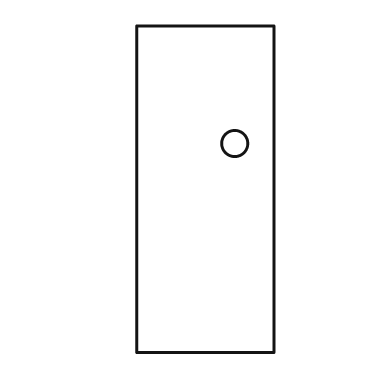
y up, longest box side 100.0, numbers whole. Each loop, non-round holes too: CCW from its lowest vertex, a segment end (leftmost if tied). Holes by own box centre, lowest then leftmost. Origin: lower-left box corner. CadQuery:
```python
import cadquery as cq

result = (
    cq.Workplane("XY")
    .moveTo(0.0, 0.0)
    .lineTo(42.0, 0.0)
    .lineTo(42.0, 100.0)
    .lineTo(0.0, 100.0)
    .close()
    .moveTo(30.0, 64.0)
    .circle(4.0)
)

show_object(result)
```